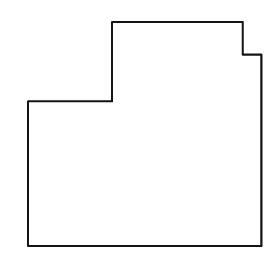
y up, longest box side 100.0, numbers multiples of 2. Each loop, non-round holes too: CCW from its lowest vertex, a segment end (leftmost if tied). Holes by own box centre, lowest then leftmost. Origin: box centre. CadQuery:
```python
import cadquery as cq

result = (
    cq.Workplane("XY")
    .moveTo(-50.0, -48.0)
    .lineTo(50.0, -48.0)
    .lineTo(50.0, 34.0)
    .lineTo(42.0, 34.0)
    .lineTo(42.0, 48.0)
    .lineTo(-14.0, 48.0)
    .lineTo(-14.0, 14.0)
    .lineTo(-50.0, 14.0)
    .close()
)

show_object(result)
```